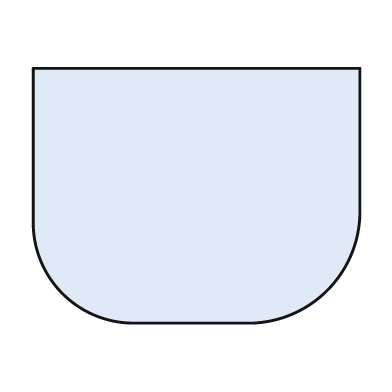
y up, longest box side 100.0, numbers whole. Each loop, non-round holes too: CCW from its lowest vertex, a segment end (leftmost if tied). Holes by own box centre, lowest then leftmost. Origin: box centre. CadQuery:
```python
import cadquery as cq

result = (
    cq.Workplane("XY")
    .moveTo(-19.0, -39.0)
    .lineTo(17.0, -39.0)
    .threePointArc((40.0, -29.0), (50.0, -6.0))
    .lineTo(50.0, 39.0)
    .lineTo(-50.0, 39.0)
    .lineTo(-50.0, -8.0)
    .threePointArc((-41.0, -30.0), (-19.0, -39.0))
    .close()
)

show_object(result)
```